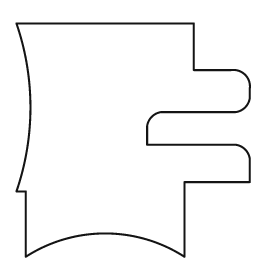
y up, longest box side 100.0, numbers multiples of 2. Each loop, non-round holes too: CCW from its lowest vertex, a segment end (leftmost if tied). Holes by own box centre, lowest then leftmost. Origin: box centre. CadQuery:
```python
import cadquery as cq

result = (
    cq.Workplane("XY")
    .moveTo(-46.0, -50.0)
    .threePointArc((-12.0, -40.0), (22.0, -50.0))
    .lineTo(22.0, -18.0)
    .lineTo(50.0, -18.0)
    .lineTo(50.0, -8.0)
    .threePointArc((48.0, -4.0), (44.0, -2.0))
    .lineTo(6.0, -2.0)
    .lineTo(6.0, 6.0)
    .threePointArc((8.0, 10.0), (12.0, 12.0))
    .lineTo(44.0, 12.0)
    .threePointArc((48.0, 14.0), (50.0, 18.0))
    .lineTo(50.0, 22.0)
    .threePointArc((48.0, 28.0), (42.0, 30.0))
    .lineTo(26.0, 30.0)
    .lineTo(26.0, 50.0)
    .lineTo(-50.0, 50.0)
    .threePointArc((-44.0, 14.0), (-50.0, -22.0))
    .lineTo(-46.0, -22.0)
    .close()
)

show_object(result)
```